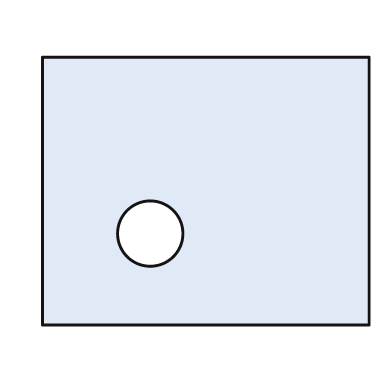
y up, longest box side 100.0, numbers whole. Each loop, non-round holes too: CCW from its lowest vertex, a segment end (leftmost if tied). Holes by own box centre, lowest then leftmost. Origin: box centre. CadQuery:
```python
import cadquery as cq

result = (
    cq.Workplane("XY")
    .moveTo(-50.0, -41.0)
    .lineTo(50.0, -41.0)
    .lineTo(50.0, 41.0)
    .lineTo(-50.0, 41.0)
    .close()
    .moveTo(-17.0, -13.0)
    .circle(10.0)
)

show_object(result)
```